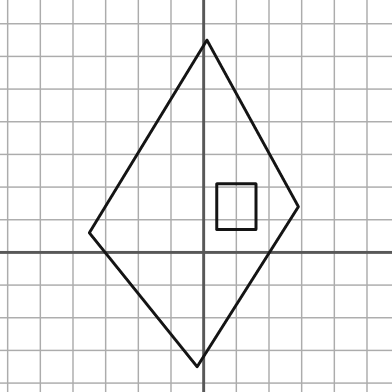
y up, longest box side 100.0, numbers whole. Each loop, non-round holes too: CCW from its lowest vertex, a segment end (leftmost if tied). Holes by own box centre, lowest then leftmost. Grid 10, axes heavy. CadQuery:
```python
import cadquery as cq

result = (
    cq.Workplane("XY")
    .moveTo(-2.0, -35.0)
    .lineTo(29.0, 14.0)
    .lineTo(1.0, 65.0)
    .lineTo(-35.0, 6.0)
    .close()
    .moveTo(4.0, 7.0)
    .lineTo(16.0, 7.0)
    .lineTo(16.0, 21.0)
    .lineTo(4.0, 21.0)
    .close()
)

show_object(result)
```